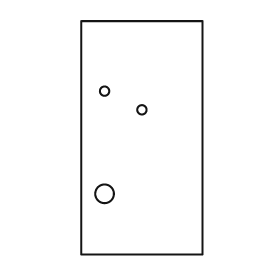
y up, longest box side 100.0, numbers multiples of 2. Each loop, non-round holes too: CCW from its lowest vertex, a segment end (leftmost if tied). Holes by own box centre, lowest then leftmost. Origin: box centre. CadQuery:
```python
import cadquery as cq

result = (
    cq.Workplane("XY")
    .moveTo(-26.0, -50.0)
    .lineTo(26.0, -50.0)
    .lineTo(26.0, 50.0)
    .lineTo(-26.0, 50.0)
    .close()
    .moveTo(-16.0, -24.0)
    .circle(4.0)
    .moveTo(0.0, 12.0)
    .circle(2.0)
    .moveTo(-16.0, 20.0)
    .circle(2.0)
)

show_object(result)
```